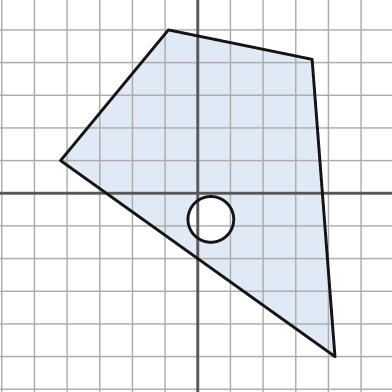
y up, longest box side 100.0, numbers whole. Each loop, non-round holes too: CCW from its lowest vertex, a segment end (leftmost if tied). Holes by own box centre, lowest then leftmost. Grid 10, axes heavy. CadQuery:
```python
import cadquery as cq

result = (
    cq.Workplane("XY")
    .moveTo(42.0, -50.0)
    .lineTo(35.0, 41.0)
    .lineTo(-9.0, 50.0)
    .lineTo(-42.0, 10.0)
    .close()
    .moveTo(4.0, -8.0)
    .circle(7.0)
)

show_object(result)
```